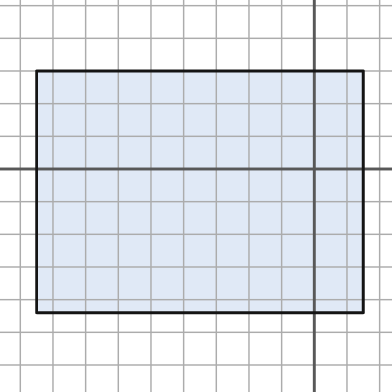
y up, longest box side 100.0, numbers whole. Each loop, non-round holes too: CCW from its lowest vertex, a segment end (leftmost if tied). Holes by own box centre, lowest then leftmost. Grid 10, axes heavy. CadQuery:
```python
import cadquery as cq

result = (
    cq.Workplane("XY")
    .moveTo(-85.0, -44.0)
    .lineTo(15.0, -44.0)
    .lineTo(15.0, 30.0)
    .lineTo(-85.0, 30.0)
    .close()
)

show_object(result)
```